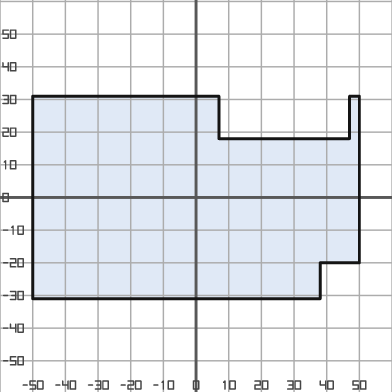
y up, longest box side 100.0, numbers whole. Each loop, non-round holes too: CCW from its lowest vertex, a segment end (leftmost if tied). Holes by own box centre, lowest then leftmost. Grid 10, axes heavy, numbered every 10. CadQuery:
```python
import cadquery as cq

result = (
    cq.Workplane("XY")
    .moveTo(-50.0, -31.0)
    .lineTo(38.0, -31.0)
    .lineTo(38.0, -20.0)
    .lineTo(50.0, -20.0)
    .lineTo(50.0, 31.0)
    .lineTo(47.0, 31.0)
    .lineTo(47.0, 18.0)
    .lineTo(7.0, 18.0)
    .lineTo(7.0, 31.0)
    .lineTo(-50.0, 31.0)
    .close()
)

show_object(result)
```